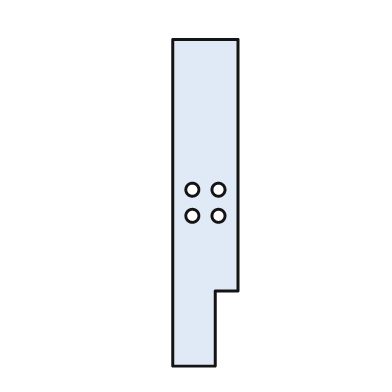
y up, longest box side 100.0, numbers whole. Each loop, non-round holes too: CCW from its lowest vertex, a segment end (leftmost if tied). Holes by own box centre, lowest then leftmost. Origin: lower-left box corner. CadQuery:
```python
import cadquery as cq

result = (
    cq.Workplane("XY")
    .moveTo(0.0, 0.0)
    .lineTo(13.0, 0.0)
    .lineTo(13.0, 23.0)
    .lineTo(20.0, 23.0)
    .lineTo(20.0, 100.0)
    .lineTo(0.0, 100.0)
    .close()
    .moveTo(6.0, 46.0)
    .circle(2.0)
    .moveTo(14.0, 46.0)
    .circle(2.0)
    .moveTo(6.0, 54.0)
    .circle(2.0)
    .moveTo(14.0, 54.0)
    .circle(2.0)
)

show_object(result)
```